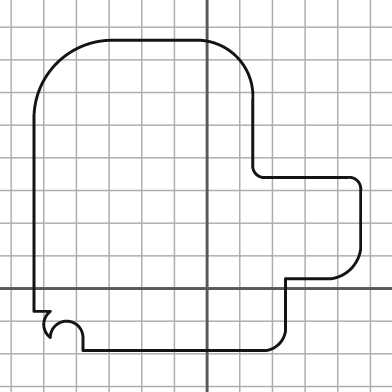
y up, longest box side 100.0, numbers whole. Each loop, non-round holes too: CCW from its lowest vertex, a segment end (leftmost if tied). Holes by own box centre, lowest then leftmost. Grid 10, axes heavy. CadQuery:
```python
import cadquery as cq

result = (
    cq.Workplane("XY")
    .moveTo(-38.0, -19.0)
    .lineTo(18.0, -19.0)
    .threePointArc((22.0, -17.0), (24.0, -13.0))
    .lineTo(24.0, 3.0)
    .lineTo(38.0, 3.0)
    .threePointArc((44.0, 6.0), (47.0, 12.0))
    .lineTo(47.0, 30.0)
    .threePointArc((46.0, 33.0), (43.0, 34.0))
    .lineTo(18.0, 34.0)
    .threePointArc((15.0, 35.0), (14.0, 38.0))
    .lineTo(14.0, 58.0)
    .threePointArc((9.0, 71.0), (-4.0, 76.0))
    .lineTo(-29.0, 76.0)
    .threePointArc((-46.0, 69.0), (-53.0, 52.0))
    .lineTo(-53.0, -7.0)
    .lineTo(-48.0, -7.0)
    .threePointArc((-50.0, -11.0), (-48.0, -15.0))
    .threePointArc((-43.0, -10.0), (-38.0, -15.0))
    .close()
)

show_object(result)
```